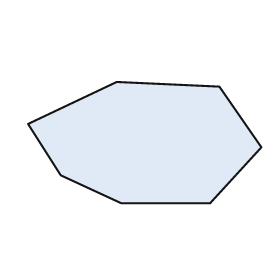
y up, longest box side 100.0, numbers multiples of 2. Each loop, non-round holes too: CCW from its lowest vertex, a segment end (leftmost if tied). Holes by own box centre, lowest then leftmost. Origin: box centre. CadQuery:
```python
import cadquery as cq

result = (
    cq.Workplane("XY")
    .moveTo(-10.0, -26.0)
    .lineTo(28.0, -26.0)
    .lineTo(50.0, -2.0)
    .lineTo(32.0, 24.0)
    .lineTo(-12.0, 26.0)
    .lineTo(-50.0, 8.0)
    .lineTo(-36.0, -14.0)
    .close()
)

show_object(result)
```